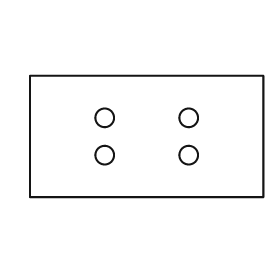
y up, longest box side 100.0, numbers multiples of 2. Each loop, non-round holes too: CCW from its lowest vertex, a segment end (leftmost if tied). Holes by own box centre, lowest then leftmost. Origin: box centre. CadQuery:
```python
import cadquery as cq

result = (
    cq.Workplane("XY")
    .moveTo(-50.0, -26.0)
    .lineTo(50.0, -26.0)
    .lineTo(50.0, 26.0)
    .lineTo(-50.0, 26.0)
    .close()
    .moveTo(-18.0, -8.0)
    .circle(4.0)
    .moveTo(18.0, -8.0)
    .circle(4.0)
    .moveTo(-18.0, 8.0)
    .circle(4.0)
    .moveTo(18.0, 8.0)
    .circle(4.0)
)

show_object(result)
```